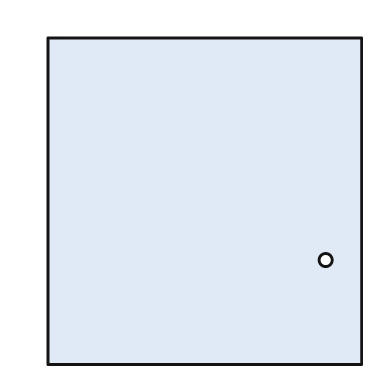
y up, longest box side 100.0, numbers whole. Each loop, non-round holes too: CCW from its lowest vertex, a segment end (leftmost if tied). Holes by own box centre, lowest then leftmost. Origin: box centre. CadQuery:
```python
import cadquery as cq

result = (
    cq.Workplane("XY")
    .moveTo(-48.0, -50.0)
    .lineTo(48.0, -50.0)
    .lineTo(48.0, 50.0)
    .lineTo(-48.0, 50.0)
    .close()
    .moveTo(37.0, -18.0)
    .circle(2.0)
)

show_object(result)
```